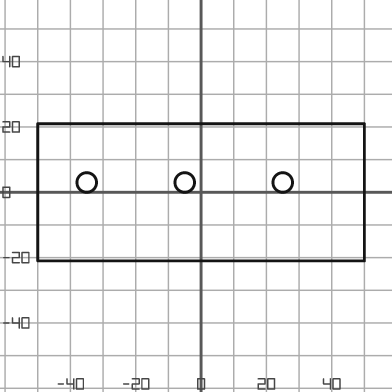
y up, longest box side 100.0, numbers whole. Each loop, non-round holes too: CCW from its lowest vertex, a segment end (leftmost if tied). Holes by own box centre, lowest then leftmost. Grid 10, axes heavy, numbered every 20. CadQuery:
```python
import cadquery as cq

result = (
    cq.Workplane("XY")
    .moveTo(-50.0, -21.0)
    .lineTo(50.0, -21.0)
    .lineTo(50.0, 21.0)
    .lineTo(-50.0, 21.0)
    .close()
    .moveTo(-35.0, 3.0)
    .circle(3.0)
    .moveTo(-5.0, 3.0)
    .circle(3.0)
    .moveTo(25.0, 3.0)
    .circle(3.0)
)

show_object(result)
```